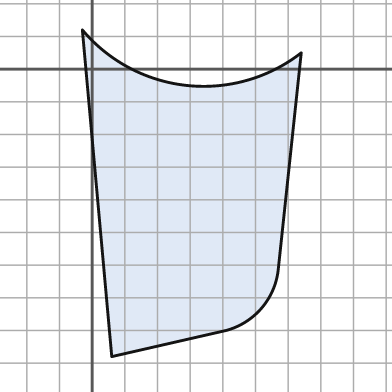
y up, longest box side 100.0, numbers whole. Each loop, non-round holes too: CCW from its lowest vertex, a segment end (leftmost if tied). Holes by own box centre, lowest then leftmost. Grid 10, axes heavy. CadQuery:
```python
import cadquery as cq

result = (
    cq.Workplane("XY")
    .moveTo(6.0, -88.0)
    .lineTo(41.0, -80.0)
    .threePointArc((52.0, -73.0), (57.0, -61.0))
    .lineTo(64.0, 5.0)
    .threePointArc((29.0, -5.0), (-3.0, 12.0))
    .close()
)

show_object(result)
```